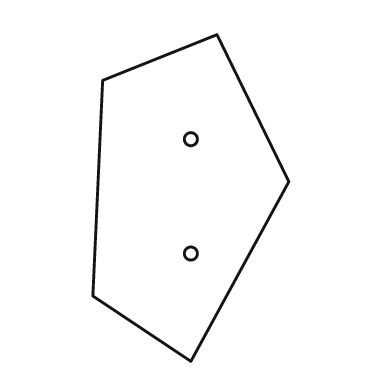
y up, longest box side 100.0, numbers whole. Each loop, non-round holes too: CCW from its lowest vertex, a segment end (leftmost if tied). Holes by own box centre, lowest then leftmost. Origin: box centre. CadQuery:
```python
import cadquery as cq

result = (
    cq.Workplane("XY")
    .moveTo(0.0, -50.0)
    .lineTo(30.0, 5.0)
    .lineTo(8.0, 50.0)
    .lineTo(-27.0, 36.0)
    .lineTo(-30.0, -30.0)
    .close()
    .moveTo(0.0, -17.0)
    .circle(2.0)
    .moveTo(0.0, 18.0)
    .circle(2.0)
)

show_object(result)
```